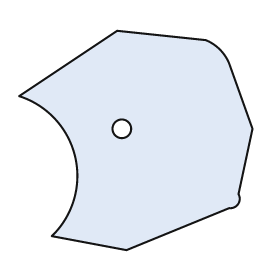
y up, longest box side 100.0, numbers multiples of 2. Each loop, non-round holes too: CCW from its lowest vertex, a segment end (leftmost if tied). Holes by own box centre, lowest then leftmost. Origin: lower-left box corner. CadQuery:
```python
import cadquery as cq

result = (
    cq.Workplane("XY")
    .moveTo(46.0, 0.0)
    .lineTo(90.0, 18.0)
    .threePointArc((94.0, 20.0), (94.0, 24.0))
    .lineTo(100.0, 52.0)
    .lineTo(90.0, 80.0)
    .threePointArc((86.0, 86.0), (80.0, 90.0))
    .lineTo(42.0, 94.0)
    .lineTo(0.0, 66.0)
    .threePointArc((24.0, 40.0), (14.0, 6.0))
    .close()
    .moveTo(44.0, 52.0)
    .circle(4.0)
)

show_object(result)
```